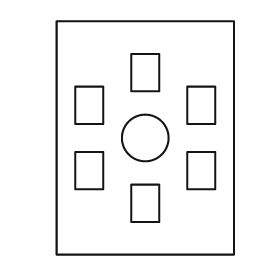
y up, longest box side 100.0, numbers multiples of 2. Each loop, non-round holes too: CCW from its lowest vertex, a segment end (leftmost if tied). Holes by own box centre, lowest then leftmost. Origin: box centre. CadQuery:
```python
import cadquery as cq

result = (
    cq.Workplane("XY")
    .moveTo(-38.0, -50.0)
    .lineTo(38.0, -50.0)
    .lineTo(38.0, 50.0)
    .lineTo(-38.0, 50.0)
    .close()
    .moveTo(-6.0, -36.0)
    .lineTo(6.0, -36.0)
    .lineTo(6.0, -20.0)
    .lineTo(-6.0, -20.0)
    .close()
    .moveTo(-30.0, -22.0)
    .lineTo(-18.0, -22.0)
    .lineTo(-18.0, -6.0)
    .lineTo(-30.0, -6.0)
    .close()
    .moveTo(18.0, -22.0)
    .lineTo(30.0, -22.0)
    .lineTo(30.0, -6.0)
    .lineTo(18.0, -6.0)
    .close()
    .moveTo(0.0, 0.0)
    .circle(10.0)
    .moveTo(-30.0, 6.0)
    .lineTo(-18.0, 6.0)
    .lineTo(-18.0, 22.0)
    .lineTo(-30.0, 22.0)
    .close()
    .moveTo(18.0, 6.0)
    .lineTo(30.0, 6.0)
    .lineTo(30.0, 22.0)
    .lineTo(18.0, 22.0)
    .close()
    .moveTo(-6.0, 20.0)
    .lineTo(6.0, 20.0)
    .lineTo(6.0, 36.0)
    .lineTo(-6.0, 36.0)
    .close()
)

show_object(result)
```